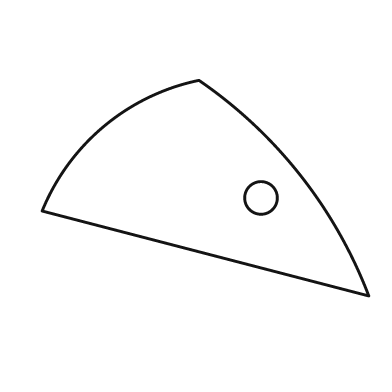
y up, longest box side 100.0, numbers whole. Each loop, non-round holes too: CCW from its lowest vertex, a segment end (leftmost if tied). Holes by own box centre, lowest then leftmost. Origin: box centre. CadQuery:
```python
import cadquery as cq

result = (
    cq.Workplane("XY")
    .moveTo(50.0, -33.0)
    .threePointArc((29.0, 4.0), (-2.0, 33.0))
    .threePointArc((-31.0, 19.0), (-50.0, -7.0))
    .close()
    .moveTo(17.0, -3.0)
    .circle(5.0)
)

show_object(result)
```